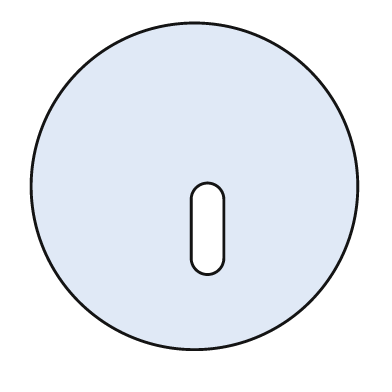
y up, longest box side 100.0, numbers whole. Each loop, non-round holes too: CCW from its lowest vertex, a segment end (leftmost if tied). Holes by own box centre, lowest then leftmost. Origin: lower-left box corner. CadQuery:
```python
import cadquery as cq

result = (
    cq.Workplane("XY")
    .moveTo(50.0, 50.0)
    .circle(50.0)
    .moveTo(49.0, 28.0)
    .threePointArc((54.0, 23.0), (59.0, 28.0))
    .lineTo(59.0, 46.0)
    .threePointArc((54.0, 51.0), (49.0, 46.0))
    .close()
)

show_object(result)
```